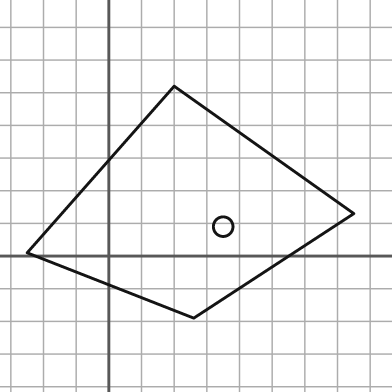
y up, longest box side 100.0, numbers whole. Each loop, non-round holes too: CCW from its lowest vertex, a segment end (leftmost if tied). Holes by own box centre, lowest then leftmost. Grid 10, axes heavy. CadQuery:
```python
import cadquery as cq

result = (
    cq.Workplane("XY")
    .moveTo(26.0, -19.0)
    .lineTo(75.0, 13.0)
    .lineTo(20.0, 52.0)
    .lineTo(-25.0, 1.0)
    .close()
    .moveTo(35.0, 9.0)
    .circle(3.0)
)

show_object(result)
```